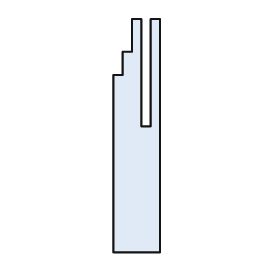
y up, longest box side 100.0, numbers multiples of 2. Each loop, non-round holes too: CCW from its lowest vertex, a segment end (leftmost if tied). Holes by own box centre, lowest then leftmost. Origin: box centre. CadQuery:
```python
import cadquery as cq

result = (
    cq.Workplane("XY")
    .moveTo(-10.0, -50.0)
    .lineTo(10.0, -50.0)
    .lineTo(10.0, 50.0)
    .lineTo(6.0, 50.0)
    .lineTo(6.0, 4.0)
    .lineTo(2.0, 4.0)
    .lineTo(2.0, 50.0)
    .lineTo(-2.0, 50.0)
    .lineTo(-2.0, 36.0)
    .lineTo(-6.0, 36.0)
    .lineTo(-6.0, 26.0)
    .lineTo(-10.0, 26.0)
    .close()
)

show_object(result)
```